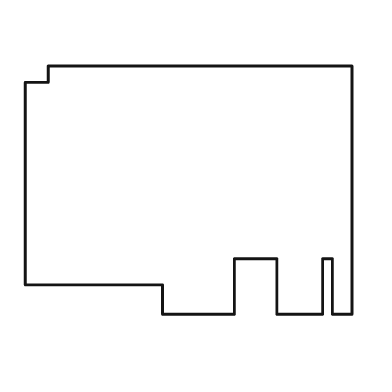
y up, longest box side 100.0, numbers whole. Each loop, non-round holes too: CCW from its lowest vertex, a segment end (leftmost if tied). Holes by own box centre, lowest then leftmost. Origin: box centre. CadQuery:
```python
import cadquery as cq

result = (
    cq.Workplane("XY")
    .moveTo(-8.0, -38.0)
    .lineTo(14.0, -38.0)
    .lineTo(14.0, -21.0)
    .lineTo(27.0, -21.0)
    .lineTo(27.0, -38.0)
    .lineTo(41.0, -38.0)
    .lineTo(41.0, -21.0)
    .lineTo(44.0, -21.0)
    .lineTo(44.0, -38.0)
    .lineTo(50.0, -38.0)
    .lineTo(50.0, 38.0)
    .lineTo(-43.0, 38.0)
    .lineTo(-43.0, 33.0)
    .lineTo(-50.0, 33.0)
    .lineTo(-50.0, -29.0)
    .lineTo(-8.0, -29.0)
    .close()
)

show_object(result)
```